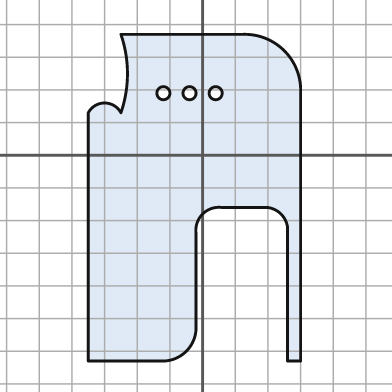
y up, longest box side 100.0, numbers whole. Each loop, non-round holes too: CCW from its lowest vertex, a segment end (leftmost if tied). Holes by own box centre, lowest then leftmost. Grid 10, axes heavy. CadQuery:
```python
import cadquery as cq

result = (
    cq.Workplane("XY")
    .moveTo(-35.0, -63.0)
    .lineTo(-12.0, -63.0)
    .threePointArc((-5.0, -60.0), (-2.0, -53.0))
    .lineTo(-2.0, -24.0)
    .threePointArc((0.0, -18.0), (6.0, -16.0))
    .lineTo(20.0, -16.0)
    .threePointArc((24.0, -18.0), (26.0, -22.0))
    .lineTo(26.0, -63.0)
    .lineTo(30.0, -63.0)
    .lineTo(30.0, 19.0)
    .threePointArc((25.0, 32.0), (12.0, 37.0))
    .lineTo(-25.0, 37.0)
    .threePointArc((-23.0, 25.0), (-25.0, 13.0))
    .threePointArc((-30.0, 16.0), (-35.0, 13.0))
    .close()
    .moveTo(-12.0, 19.0)
    .circle(2.0)
    .moveTo(-4.0, 19.0)
    .circle(2.0)
    .moveTo(4.0, 19.0)
    .circle(2.0)
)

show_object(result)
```